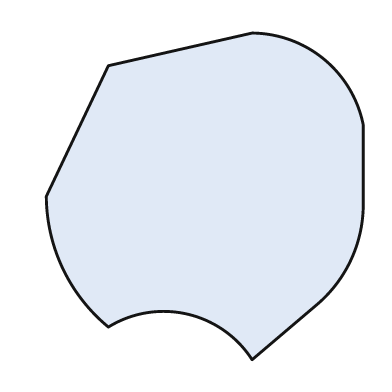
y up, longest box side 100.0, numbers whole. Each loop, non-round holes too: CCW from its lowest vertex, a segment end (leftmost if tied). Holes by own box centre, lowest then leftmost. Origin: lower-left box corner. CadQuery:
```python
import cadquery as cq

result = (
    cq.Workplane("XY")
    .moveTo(63.0, 0.0)
    .lineTo(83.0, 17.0)
    .threePointArc((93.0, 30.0), (97.0, 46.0))
    .lineTo(97.0, 72.0)
    .threePointArc((85.0, 92.0), (63.0, 100.0))
    .lineTo(19.0, 90.0)
    .lineTo(0.0, 50.0)
    .threePointArc((5.0, 28.0), (19.0, 10.0))
    .threePointArc((43.0, 14.0), (63.0, 0.0))
    .close()
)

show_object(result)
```